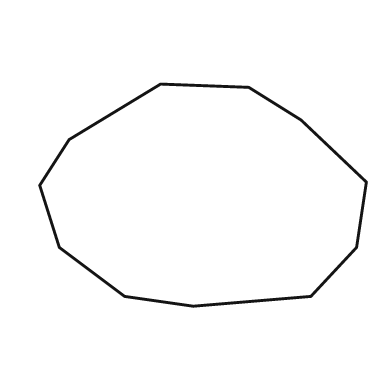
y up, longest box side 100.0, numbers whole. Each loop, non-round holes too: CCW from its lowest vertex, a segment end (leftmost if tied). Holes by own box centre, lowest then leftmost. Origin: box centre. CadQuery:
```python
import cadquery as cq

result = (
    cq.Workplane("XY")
    .moveTo(-3.0, -34.0)
    .lineTo(33.0, -31.0)
    .lineTo(47.0, -16.0)
    .lineTo(50.0, 4.0)
    .lineTo(30.0, 23.0)
    .lineTo(14.0, 33.0)
    .lineTo(-13.0, 34.0)
    .lineTo(-41.0, 17.0)
    .lineTo(-50.0, 3.0)
    .lineTo(-44.0, -16.0)
    .lineTo(-24.0, -31.0)
    .close()
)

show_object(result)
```